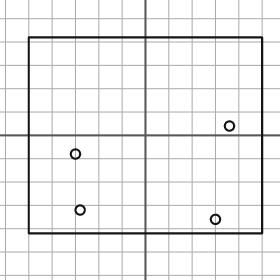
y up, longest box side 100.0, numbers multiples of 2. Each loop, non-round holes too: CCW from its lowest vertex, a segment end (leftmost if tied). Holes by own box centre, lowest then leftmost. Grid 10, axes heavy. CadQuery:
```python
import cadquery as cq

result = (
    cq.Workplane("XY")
    .moveTo(-50.0, -42.0)
    .lineTo(50.0, -42.0)
    .lineTo(50.0, 42.0)
    .lineTo(-50.0, 42.0)
    .close()
    .moveTo(30.0, -36.0)
    .circle(2.0)
    .moveTo(-28.0, -32.0)
    .circle(2.0)
    .moveTo(-30.0, -8.0)
    .circle(2.0)
    .moveTo(36.0, 4.0)
    .circle(2.0)
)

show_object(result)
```